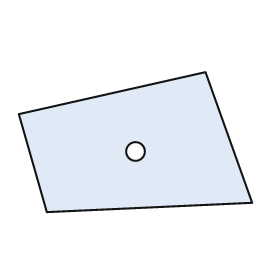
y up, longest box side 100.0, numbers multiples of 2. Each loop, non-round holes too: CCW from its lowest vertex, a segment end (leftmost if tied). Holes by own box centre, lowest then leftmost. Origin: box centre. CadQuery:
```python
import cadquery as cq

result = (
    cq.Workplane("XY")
    .moveTo(-38.0, -30.0)
    .lineTo(50.0, -26.0)
    .lineTo(30.0, 30.0)
    .lineTo(-50.0, 12.0)
    .close()
    .moveTo(0.0, -4.0)
    .circle(4.0)
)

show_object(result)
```